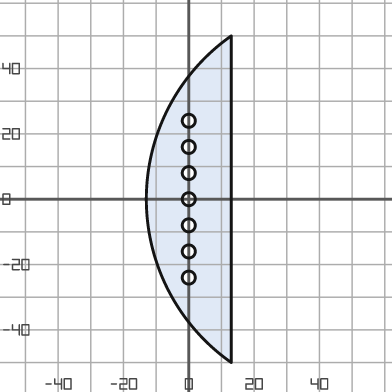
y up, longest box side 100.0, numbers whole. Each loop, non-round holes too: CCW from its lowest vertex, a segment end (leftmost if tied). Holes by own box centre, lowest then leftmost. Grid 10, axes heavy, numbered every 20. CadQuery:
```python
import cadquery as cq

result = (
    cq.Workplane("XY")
    .moveTo(13.0, -50.0)
    .lineTo(13.0, 50.0)
    .threePointArc((-13.0, 0.0), (13.0, -50.0))
    .close()
    .moveTo(0.0, -24.0)
    .circle(2.0)
    .moveTo(0.0, -16.0)
    .circle(2.0)
    .moveTo(0.0, -8.0)
    .circle(2.0)
    .moveTo(0.0, 0.0)
    .circle(2.0)
    .moveTo(0.0, 8.0)
    .circle(2.0)
    .moveTo(0.0, 16.0)
    .circle(2.0)
    .moveTo(0.0, 24.0)
    .circle(2.0)
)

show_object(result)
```